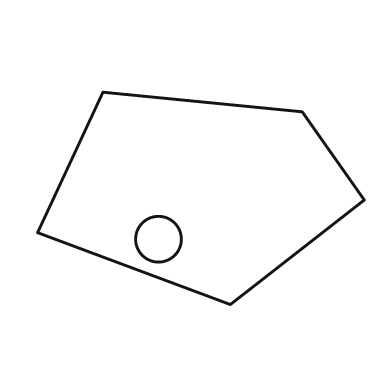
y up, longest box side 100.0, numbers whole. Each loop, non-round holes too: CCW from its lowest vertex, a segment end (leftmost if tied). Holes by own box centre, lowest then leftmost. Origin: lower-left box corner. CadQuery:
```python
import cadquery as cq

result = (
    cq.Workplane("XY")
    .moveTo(59.0, 0.0)
    .lineTo(100.0, 32.0)
    .lineTo(81.0, 59.0)
    .lineTo(20.0, 65.0)
    .lineTo(0.0, 22.0)
    .close()
    .moveTo(37.0, 20.0)
    .circle(7.0)
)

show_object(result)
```